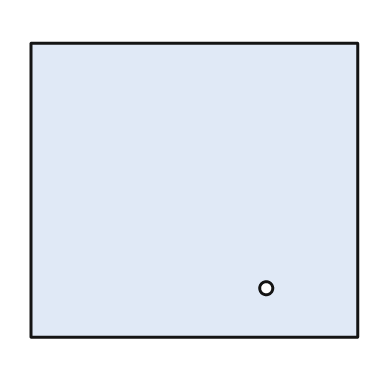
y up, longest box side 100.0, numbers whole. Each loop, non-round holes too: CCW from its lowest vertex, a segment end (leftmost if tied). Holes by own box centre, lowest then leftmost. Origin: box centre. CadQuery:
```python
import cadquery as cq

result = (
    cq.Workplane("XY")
    .moveTo(-50.0, -45.0)
    .lineTo(50.0, -45.0)
    .lineTo(50.0, 45.0)
    .lineTo(-50.0, 45.0)
    .close()
    .moveTo(22.0, -30.0)
    .circle(2.0)
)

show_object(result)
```